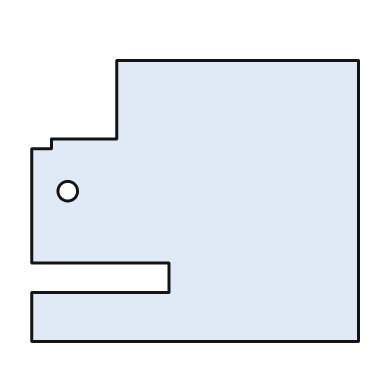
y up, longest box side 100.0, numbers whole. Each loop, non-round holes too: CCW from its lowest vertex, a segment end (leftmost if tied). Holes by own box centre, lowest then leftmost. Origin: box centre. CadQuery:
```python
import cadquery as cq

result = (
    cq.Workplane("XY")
    .moveTo(-50.0, -43.0)
    .lineTo(50.0, -43.0)
    .lineTo(50.0, 43.0)
    .lineTo(-24.0, 43.0)
    .lineTo(-24.0, 19.0)
    .lineTo(-44.0, 19.0)
    .lineTo(-44.0, 16.0)
    .lineTo(-50.0, 16.0)
    .lineTo(-50.0, -19.0)
    .lineTo(-8.0, -19.0)
    .lineTo(-8.0, -28.0)
    .lineTo(-50.0, -28.0)
    .close()
    .moveTo(-39.0, 3.0)
    .circle(3.0)
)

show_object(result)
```